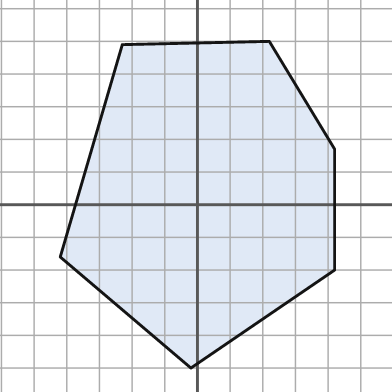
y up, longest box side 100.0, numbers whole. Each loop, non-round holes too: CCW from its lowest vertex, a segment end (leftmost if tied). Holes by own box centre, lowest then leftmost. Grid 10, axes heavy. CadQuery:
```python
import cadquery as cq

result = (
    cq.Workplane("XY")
    .moveTo(-2.0, -50.0)
    .lineTo(42.0, -20.0)
    .lineTo(42.0, 17.0)
    .lineTo(22.0, 50.0)
    .lineTo(-23.0, 49.0)
    .lineTo(-42.0, -16.0)
    .close()
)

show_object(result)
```